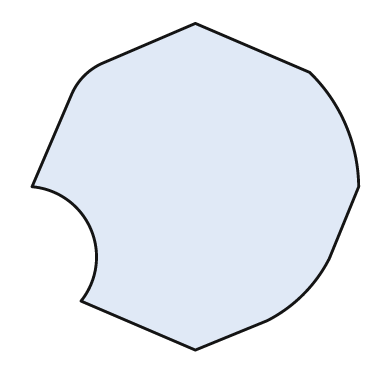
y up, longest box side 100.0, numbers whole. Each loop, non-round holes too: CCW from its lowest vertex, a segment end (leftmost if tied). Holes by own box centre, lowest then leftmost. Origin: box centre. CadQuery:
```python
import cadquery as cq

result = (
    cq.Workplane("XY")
    .moveTo(0.0, -50.0)
    .lineTo(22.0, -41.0)
    .threePointArc((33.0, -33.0), (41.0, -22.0))
    .lineTo(50.0, 0.0)
    .threePointArc((46.0, 19.0), (35.0, 35.0))
    .lineTo(0.0, 50.0)
    .lineTo(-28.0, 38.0)
    .threePointArc((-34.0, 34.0), (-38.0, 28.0))
    .lineTo(-50.0, 0.0)
    .threePointArc((-32.0, -13.0), (-35.0, -35.0))
    .close()
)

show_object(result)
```